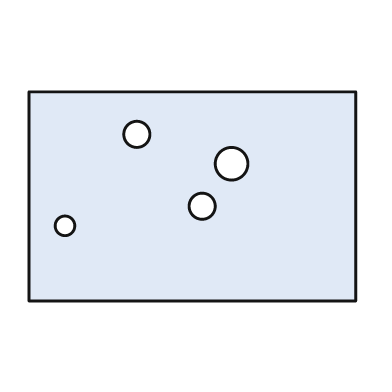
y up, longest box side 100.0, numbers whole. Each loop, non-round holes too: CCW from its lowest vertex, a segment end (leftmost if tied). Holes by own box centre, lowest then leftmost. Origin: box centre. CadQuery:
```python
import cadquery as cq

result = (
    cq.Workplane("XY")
    .moveTo(-50.0, -32.0)
    .lineTo(50.0, -32.0)
    .lineTo(50.0, 32.0)
    .lineTo(-50.0, 32.0)
    .close()
    .moveTo(-39.0, -9.0)
    .circle(3.0)
    .moveTo(3.0, -3.0)
    .circle(4.0)
    .moveTo(12.0, 10.0)
    .circle(5.0)
    .moveTo(-17.0, 19.0)
    .circle(4.0)
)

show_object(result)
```